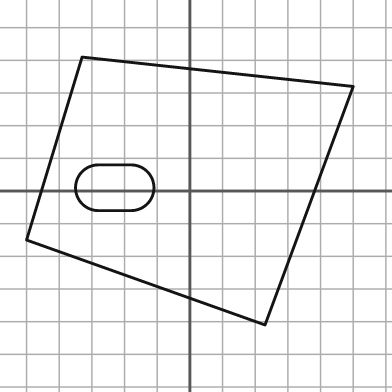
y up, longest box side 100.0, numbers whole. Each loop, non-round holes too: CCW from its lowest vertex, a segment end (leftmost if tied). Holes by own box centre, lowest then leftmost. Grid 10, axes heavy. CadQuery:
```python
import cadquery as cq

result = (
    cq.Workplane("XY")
    .moveTo(23.0, -41.0)
    .lineTo(50.0, 32.0)
    .lineTo(-33.0, 41.0)
    .lineTo(-50.0, -15.0)
    .close()
    .moveTo(-28.0, -6.0)
    .lineTo(-18.0, -6.0)
    .threePointArc((-11.0, 1.0), (-18.0, 8.0))
    .lineTo(-28.0, 8.0)
    .threePointArc((-35.0, 1.0), (-28.0, -6.0))
    .close()
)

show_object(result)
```